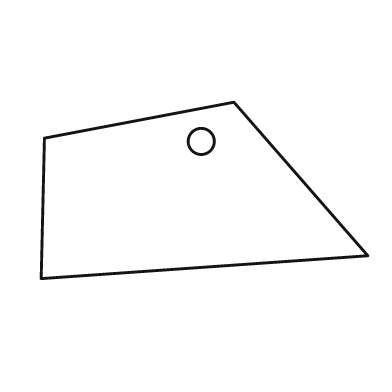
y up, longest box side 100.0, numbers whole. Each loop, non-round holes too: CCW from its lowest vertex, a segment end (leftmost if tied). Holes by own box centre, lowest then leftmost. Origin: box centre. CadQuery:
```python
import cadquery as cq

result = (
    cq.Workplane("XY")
    .moveTo(-50.0, -27.0)
    .lineTo(50.0, -20.0)
    .lineTo(9.0, 27.0)
    .lineTo(-49.0, 16.0)
    .close()
    .moveTo(-1.0, 15.0)
    .circle(4.0)
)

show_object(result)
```